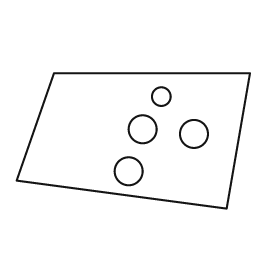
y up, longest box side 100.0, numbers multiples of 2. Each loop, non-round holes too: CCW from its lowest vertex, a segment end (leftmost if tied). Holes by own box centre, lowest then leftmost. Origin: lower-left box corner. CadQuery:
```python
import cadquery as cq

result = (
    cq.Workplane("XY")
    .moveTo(90.0, 0.0)
    .lineTo(100.0, 58.0)
    .lineTo(16.0, 58.0)
    .lineTo(0.0, 12.0)
    .close()
    .moveTo(48.0, 16.0)
    .circle(6.0)
    .moveTo(76.0, 32.0)
    .circle(6.0)
    .moveTo(54.0, 34.0)
    .circle(6.0)
    .moveTo(62.0, 48.0)
    .circle(4.0)
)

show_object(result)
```